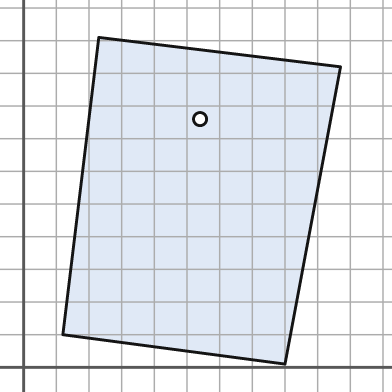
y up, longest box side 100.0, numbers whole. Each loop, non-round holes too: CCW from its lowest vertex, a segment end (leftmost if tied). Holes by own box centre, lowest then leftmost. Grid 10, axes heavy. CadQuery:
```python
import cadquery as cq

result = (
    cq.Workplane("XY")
    .moveTo(80.0, 1.0)
    .lineTo(97.0, 92.0)
    .lineTo(23.0, 101.0)
    .lineTo(12.0, 10.0)
    .close()
    .moveTo(54.0, 76.0)
    .circle(2.0)
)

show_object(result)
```